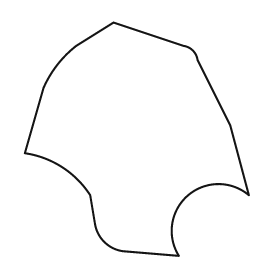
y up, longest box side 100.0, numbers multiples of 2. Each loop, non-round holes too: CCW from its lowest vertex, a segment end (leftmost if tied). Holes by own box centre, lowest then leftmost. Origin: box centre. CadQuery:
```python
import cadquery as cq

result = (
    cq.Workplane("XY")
    .moveTo(18.0, -50.0)
    .threePointArc((22.0, -24.0), (48.0, -24.0))
    .lineTo(40.0, 6.0)
    .lineTo(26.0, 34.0)
    .threePointArc((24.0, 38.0), (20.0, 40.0))
    .lineTo(-10.0, 50.0)
    .lineTo(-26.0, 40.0)
    .threePointArc((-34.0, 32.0), (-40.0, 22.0))
    .lineTo(-48.0, -6.0)
    .threePointArc((-32.0, -12.0), (-20.0, -24.0))
    .lineTo(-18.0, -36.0)
    .threePointArc((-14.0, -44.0), (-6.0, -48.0))
    .close()
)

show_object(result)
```